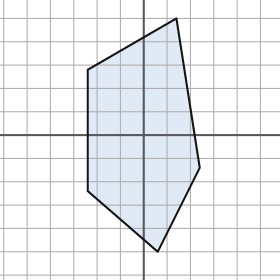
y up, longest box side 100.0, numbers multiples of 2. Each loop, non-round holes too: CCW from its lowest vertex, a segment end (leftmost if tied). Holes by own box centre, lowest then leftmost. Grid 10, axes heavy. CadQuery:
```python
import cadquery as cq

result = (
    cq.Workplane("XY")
    .moveTo(6.0, -50.0)
    .lineTo(24.0, -14.0)
    .lineTo(14.0, 50.0)
    .lineTo(-24.0, 28.0)
    .lineTo(-24.0, -24.0)
    .close()
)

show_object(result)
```